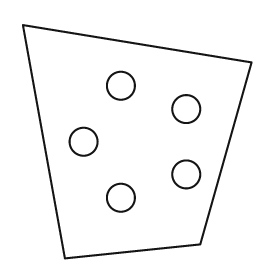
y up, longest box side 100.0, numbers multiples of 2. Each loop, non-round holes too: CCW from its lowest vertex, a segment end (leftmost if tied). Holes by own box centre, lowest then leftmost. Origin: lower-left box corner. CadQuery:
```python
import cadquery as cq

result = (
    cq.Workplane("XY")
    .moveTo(18.0, 0.0)
    .lineTo(76.0, 6.0)
    .lineTo(98.0, 84.0)
    .lineTo(0.0, 100.0)
    .close()
    .moveTo(42.0, 26.0)
    .circle(6.0)
    .moveTo(70.0, 36.0)
    .circle(6.0)
    .moveTo(26.0, 50.0)
    .circle(6.0)
    .moveTo(70.0, 64.0)
    .circle(6.0)
    .moveTo(42.0, 74.0)
    .circle(6.0)
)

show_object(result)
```